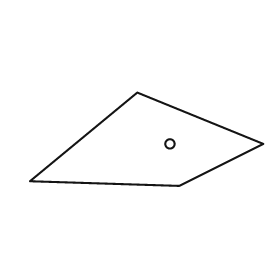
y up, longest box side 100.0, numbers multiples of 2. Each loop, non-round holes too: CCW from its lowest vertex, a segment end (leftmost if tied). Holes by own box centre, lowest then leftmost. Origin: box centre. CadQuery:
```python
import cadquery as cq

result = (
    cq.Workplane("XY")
    .moveTo(14.0, -20.0)
    .lineTo(50.0, -2.0)
    .lineTo(-4.0, 20.0)
    .lineTo(-50.0, -18.0)
    .close()
    .moveTo(10.0, -2.0)
    .circle(2.0)
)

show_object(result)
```